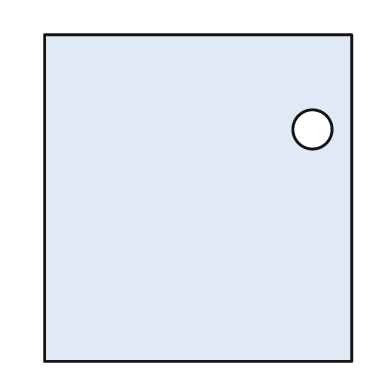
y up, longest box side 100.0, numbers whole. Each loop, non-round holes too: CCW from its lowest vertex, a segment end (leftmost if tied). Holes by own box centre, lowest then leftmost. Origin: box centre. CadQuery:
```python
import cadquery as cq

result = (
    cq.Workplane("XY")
    .moveTo(-47.0, -50.0)
    .lineTo(47.0, -50.0)
    .lineTo(47.0, 50.0)
    .lineTo(-47.0, 50.0)
    .close()
    .moveTo(35.0, 21.0)
    .circle(6.0)
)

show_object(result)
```